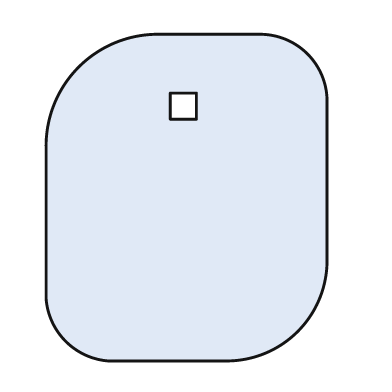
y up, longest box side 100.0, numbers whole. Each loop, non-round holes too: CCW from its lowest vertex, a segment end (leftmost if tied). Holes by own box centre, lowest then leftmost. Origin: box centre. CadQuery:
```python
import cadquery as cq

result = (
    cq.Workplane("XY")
    .moveTo(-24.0, -50.0)
    .lineTo(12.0, -50.0)
    .threePointArc((34.0, -41.0), (43.0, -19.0))
    .lineTo(43.0, 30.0)
    .threePointArc((37.0, 44.0), (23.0, 50.0))
    .lineTo(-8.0, 50.0)
    .threePointArc((-33.0, 40.0), (-43.0, 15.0))
    .lineTo(-43.0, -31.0)
    .threePointArc((-37.0, -44.0), (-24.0, -50.0))
    .close()
    .moveTo(-5.0, 24.0)
    .lineTo(3.0, 24.0)
    .lineTo(3.0, 32.0)
    .lineTo(-5.0, 32.0)
    .close()
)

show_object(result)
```